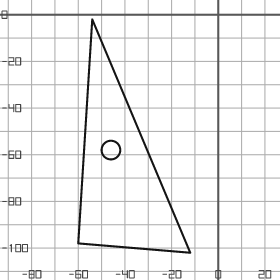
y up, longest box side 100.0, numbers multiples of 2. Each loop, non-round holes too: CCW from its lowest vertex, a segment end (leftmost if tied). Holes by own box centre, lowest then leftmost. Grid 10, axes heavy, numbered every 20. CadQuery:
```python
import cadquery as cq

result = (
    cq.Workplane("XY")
    .moveTo(-12.0, -102.0)
    .lineTo(-54.0, -2.0)
    .lineTo(-60.0, -98.0)
    .close()
    .moveTo(-46.0, -58.0)
    .circle(4.0)
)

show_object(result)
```